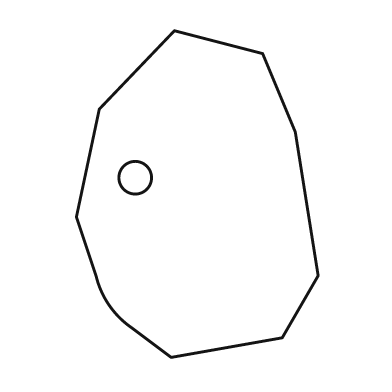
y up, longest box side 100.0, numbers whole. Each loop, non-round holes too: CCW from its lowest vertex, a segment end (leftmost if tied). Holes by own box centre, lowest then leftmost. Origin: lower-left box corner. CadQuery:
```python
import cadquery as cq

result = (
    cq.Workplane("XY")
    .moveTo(29.0, 0.0)
    .lineTo(63.0, 6.0)
    .lineTo(74.0, 25.0)
    .lineTo(67.0, 69.0)
    .lineTo(57.0, 93.0)
    .lineTo(30.0, 100.0)
    .lineTo(7.0, 76.0)
    .lineTo(0.0, 43.0)
    .lineTo(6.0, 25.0)
    .threePointArc((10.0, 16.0), (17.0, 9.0))
    .close()
    .moveTo(18.0, 55.0)
    .circle(5.0)
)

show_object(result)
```